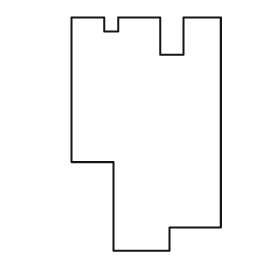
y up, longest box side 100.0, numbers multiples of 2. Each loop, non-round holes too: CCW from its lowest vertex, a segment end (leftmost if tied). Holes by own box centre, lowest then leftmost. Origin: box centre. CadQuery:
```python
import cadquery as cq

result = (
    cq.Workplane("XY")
    .moveTo(-14.0, -50.0)
    .lineTo(10.0, -50.0)
    .lineTo(10.0, -40.0)
    .lineTo(32.0, -40.0)
    .lineTo(32.0, 50.0)
    .lineTo(16.0, 50.0)
    .lineTo(16.0, 34.0)
    .lineTo(6.0, 34.0)
    .lineTo(6.0, 50.0)
    .lineTo(-12.0, 50.0)
    .lineTo(-12.0, 44.0)
    .lineTo(-18.0, 44.0)
    .lineTo(-18.0, 50.0)
    .lineTo(-32.0, 50.0)
    .lineTo(-32.0, -12.0)
    .lineTo(-14.0, -12.0)
    .close()
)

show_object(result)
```